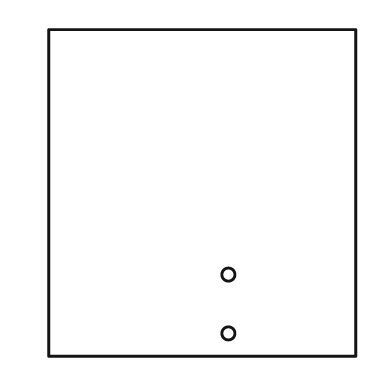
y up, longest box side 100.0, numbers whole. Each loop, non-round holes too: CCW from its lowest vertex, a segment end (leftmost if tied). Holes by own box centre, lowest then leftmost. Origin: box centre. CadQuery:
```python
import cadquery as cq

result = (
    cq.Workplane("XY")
    .moveTo(-47.0, -50.0)
    .lineTo(47.0, -50.0)
    .lineTo(47.0, 50.0)
    .lineTo(-47.0, 50.0)
    .close()
    .moveTo(8.0, -43.0)
    .circle(2.0)
    .moveTo(8.0, -25.0)
    .circle(2.0)
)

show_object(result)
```